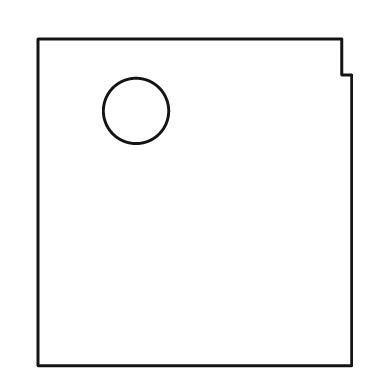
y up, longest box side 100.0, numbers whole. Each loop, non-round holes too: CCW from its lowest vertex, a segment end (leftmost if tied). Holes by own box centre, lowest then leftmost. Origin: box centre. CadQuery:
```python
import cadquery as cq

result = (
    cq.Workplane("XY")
    .moveTo(-48.0, -50.0)
    .lineTo(48.0, -50.0)
    .lineTo(48.0, 39.0)
    .lineTo(45.0, 39.0)
    .lineTo(45.0, 50.0)
    .lineTo(-48.0, 50.0)
    .close()
    .moveTo(-18.0, 28.0)
    .circle(10.0)
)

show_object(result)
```